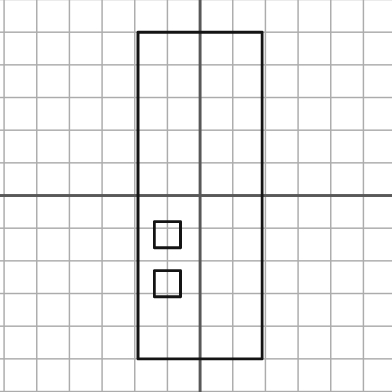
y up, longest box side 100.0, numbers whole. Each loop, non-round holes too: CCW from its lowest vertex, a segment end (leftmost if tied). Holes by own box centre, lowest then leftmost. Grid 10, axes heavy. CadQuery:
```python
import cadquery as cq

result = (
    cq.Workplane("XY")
    .moveTo(-19.0, -50.0)
    .lineTo(19.0, -50.0)
    .lineTo(19.0, 50.0)
    .lineTo(-19.0, 50.0)
    .close()
    .moveTo(-14.0, -31.0)
    .lineTo(-6.0, -31.0)
    .lineTo(-6.0, -23.0)
    .lineTo(-14.0, -23.0)
    .close()
    .moveTo(-14.0, -16.0)
    .lineTo(-6.0, -16.0)
    .lineTo(-6.0, -8.0)
    .lineTo(-14.0, -8.0)
    .close()
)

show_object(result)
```